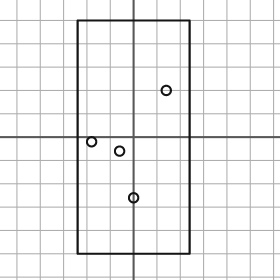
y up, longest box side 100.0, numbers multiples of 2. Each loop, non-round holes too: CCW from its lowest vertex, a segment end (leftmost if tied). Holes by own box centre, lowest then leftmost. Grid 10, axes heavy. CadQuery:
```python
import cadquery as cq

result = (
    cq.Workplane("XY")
    .moveTo(-24.0, -50.0)
    .lineTo(24.0, -50.0)
    .lineTo(24.0, 50.0)
    .lineTo(-24.0, 50.0)
    .close()
    .moveTo(0.0, -26.0)
    .circle(2.0)
    .moveTo(-6.0, -6.0)
    .circle(2.0)
    .moveTo(-18.0, -2.0)
    .circle(2.0)
    .moveTo(14.0, 20.0)
    .circle(2.0)
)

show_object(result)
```